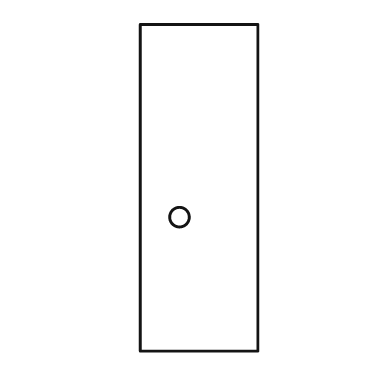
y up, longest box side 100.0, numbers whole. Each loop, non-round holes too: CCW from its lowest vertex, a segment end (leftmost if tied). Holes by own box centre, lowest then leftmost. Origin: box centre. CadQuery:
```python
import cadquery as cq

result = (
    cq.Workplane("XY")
    .moveTo(-18.0, -50.0)
    .lineTo(18.0, -50.0)
    .lineTo(18.0, 50.0)
    .lineTo(-18.0, 50.0)
    .close()
    .moveTo(-6.0, -9.0)
    .circle(3.0)
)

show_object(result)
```